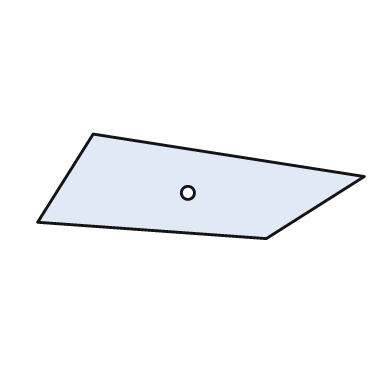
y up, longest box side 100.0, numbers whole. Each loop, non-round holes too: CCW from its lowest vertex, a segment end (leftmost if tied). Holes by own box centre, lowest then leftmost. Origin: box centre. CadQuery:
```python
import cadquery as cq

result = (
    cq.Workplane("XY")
    .moveTo(20.0, -16.0)
    .lineTo(50.0, 3.0)
    .lineTo(-33.0, 16.0)
    .lineTo(-50.0, -11.0)
    .close()
    .moveTo(-4.0, -2.0)
    .circle(2.0)
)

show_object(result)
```